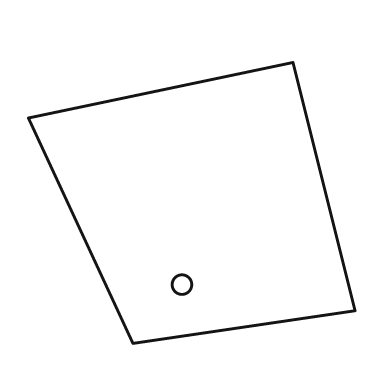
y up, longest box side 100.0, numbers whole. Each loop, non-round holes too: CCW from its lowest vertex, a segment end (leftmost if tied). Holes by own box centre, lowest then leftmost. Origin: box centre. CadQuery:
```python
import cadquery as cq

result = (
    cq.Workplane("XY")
    .moveTo(-18.0, -43.0)
    .lineTo(50.0, -33.0)
    .lineTo(31.0, 43.0)
    .lineTo(-50.0, 26.0)
    .close()
    .moveTo(-3.0, -25.0)
    .circle(3.0)
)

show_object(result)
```